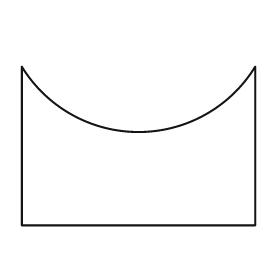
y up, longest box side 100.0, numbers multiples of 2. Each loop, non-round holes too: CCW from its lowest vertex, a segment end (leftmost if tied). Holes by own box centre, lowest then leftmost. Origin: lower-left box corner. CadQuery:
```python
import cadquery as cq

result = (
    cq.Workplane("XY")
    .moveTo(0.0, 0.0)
    .lineTo(100.0, 0.0)
    .lineTo(100.0, 68.0)
    .threePointArc((50.0, 40.0), (0.0, 68.0))
    .close()
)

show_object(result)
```